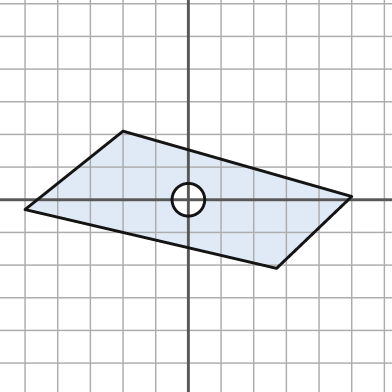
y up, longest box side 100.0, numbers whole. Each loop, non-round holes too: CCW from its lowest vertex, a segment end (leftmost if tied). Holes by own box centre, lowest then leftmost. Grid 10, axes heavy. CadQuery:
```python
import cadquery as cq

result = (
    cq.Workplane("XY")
    .moveTo(27.0, -21.0)
    .lineTo(50.0, 1.0)
    .lineTo(-20.0, 21.0)
    .lineTo(-50.0, -3.0)
    .close()
    .moveTo(0.0, 0.0)
    .circle(5.0)
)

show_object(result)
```